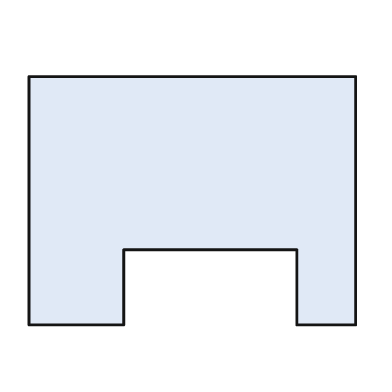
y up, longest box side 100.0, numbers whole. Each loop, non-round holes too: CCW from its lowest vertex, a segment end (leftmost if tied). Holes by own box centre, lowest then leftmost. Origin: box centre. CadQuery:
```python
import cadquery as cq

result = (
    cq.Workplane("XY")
    .moveTo(-50.0, -38.0)
    .lineTo(-21.0, -38.0)
    .lineTo(-21.0, -15.0)
    .lineTo(32.0, -15.0)
    .lineTo(32.0, -38.0)
    .lineTo(50.0, -38.0)
    .lineTo(50.0, 38.0)
    .lineTo(-50.0, 38.0)
    .close()
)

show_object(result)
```